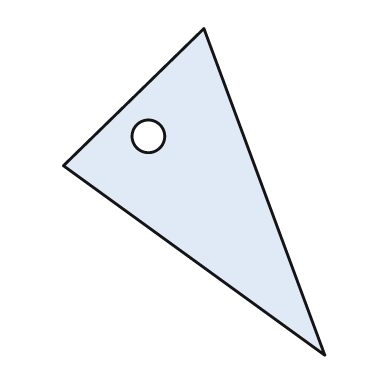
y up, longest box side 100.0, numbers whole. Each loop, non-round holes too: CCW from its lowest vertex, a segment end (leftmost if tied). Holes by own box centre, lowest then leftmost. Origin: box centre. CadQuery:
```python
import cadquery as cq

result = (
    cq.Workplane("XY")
    .moveTo(40.0, -50.0)
    .lineTo(3.0, 50.0)
    .lineTo(-40.0, 8.0)
    .close()
    .moveTo(-14.0, 17.0)
    .circle(5.0)
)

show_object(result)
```